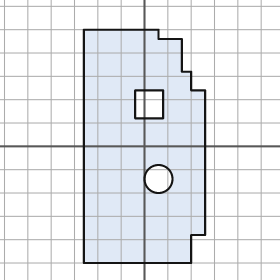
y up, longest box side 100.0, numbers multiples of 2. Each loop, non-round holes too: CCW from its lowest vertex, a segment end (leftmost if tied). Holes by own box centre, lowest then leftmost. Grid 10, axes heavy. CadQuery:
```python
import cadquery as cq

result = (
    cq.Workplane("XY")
    .moveTo(-26.0, -50.0)
    .lineTo(20.0, -50.0)
    .lineTo(20.0, -38.0)
    .lineTo(26.0, -38.0)
    .lineTo(26.0, 24.0)
    .lineTo(20.0, 24.0)
    .lineTo(20.0, 32.0)
    .lineTo(16.0, 32.0)
    .lineTo(16.0, 46.0)
    .lineTo(6.0, 46.0)
    .lineTo(6.0, 50.0)
    .lineTo(-26.0, 50.0)
    .close()
    .moveTo(6.0, -14.0)
    .circle(6.0)
    .moveTo(-4.0, 12.0)
    .lineTo(8.0, 12.0)
    .lineTo(8.0, 24.0)
    .lineTo(-4.0, 24.0)
    .close()
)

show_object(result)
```